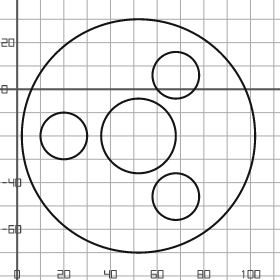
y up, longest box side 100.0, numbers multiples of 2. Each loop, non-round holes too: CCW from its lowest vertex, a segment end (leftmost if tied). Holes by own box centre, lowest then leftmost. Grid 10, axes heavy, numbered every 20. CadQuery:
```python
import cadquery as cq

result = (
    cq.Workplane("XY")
    .moveTo(52.0, -20.0)
    .circle(50.0)
    .moveTo(68.0, -46.0)
    .circle(10.0)
    .moveTo(20.0, -20.0)
    .circle(10.0)
    .moveTo(52.0, -20.0)
    .circle(16.0)
    .moveTo(68.0, 6.0)
    .circle(10.0)
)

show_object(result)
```